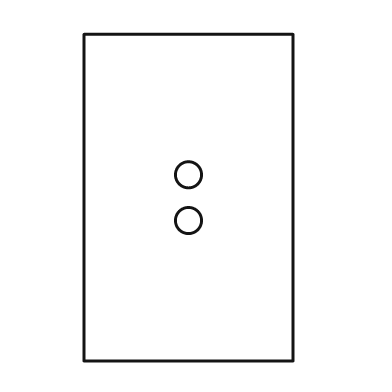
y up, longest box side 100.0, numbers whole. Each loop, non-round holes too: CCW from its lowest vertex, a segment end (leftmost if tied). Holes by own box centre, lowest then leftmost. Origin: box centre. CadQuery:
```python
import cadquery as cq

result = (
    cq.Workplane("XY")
    .moveTo(-32.0, -50.0)
    .lineTo(32.0, -50.0)
    .lineTo(32.0, 50.0)
    .lineTo(-32.0, 50.0)
    .close()
    .moveTo(0.0, -7.0)
    .circle(4.0)
    .moveTo(0.0, 7.0)
    .circle(4.0)
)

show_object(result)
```